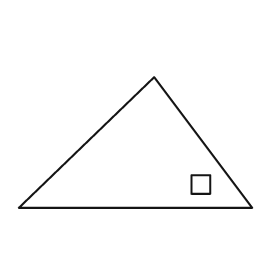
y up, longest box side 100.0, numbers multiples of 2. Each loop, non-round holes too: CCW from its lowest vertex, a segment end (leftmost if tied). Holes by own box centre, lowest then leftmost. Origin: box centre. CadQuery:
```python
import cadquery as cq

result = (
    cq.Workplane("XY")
    .moveTo(-50.0, -28.0)
    .lineTo(50.0, -28.0)
    .lineTo(8.0, 28.0)
    .close()
    .moveTo(24.0, -22.0)
    .lineTo(32.0, -22.0)
    .lineTo(32.0, -14.0)
    .lineTo(24.0, -14.0)
    .close()
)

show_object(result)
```